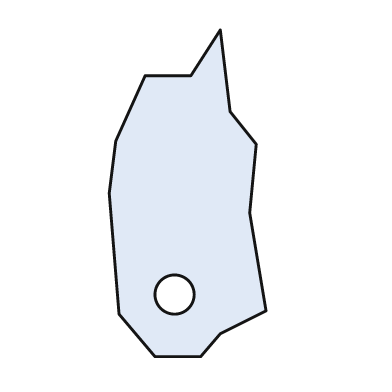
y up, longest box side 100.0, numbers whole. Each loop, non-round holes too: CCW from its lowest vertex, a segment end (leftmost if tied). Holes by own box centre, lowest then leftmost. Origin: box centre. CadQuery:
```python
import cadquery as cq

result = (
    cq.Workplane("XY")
    .moveTo(-10.0, -50.0)
    .lineTo(4.0, -50.0)
    .lineTo(10.0, -43.0)
    .lineTo(24.0, -36.0)
    .lineTo(19.0, -6.0)
    .lineTo(21.0, 15.0)
    .lineTo(13.0, 25.0)
    .lineTo(10.0, 50.0)
    .lineTo(1.0, 36.0)
    .lineTo(-13.0, 36.0)
    .lineTo(-22.0, 16.0)
    .lineTo(-24.0, 0.0)
    .lineTo(-21.0, -37.0)
    .close()
    .moveTo(-4.0, -31.0)
    .circle(6.0)
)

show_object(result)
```